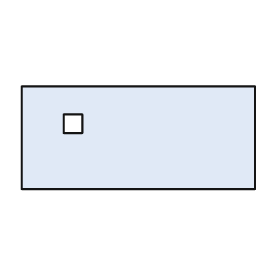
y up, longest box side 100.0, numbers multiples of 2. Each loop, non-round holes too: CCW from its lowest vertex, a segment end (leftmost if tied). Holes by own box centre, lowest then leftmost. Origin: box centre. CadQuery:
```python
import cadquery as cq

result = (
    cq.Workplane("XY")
    .moveTo(-50.0, -22.0)
    .lineTo(50.0, -22.0)
    .lineTo(50.0, 22.0)
    .lineTo(-50.0, 22.0)
    .close()
    .moveTo(-32.0, 2.0)
    .lineTo(-24.0, 2.0)
    .lineTo(-24.0, 10.0)
    .lineTo(-32.0, 10.0)
    .close()
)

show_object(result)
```